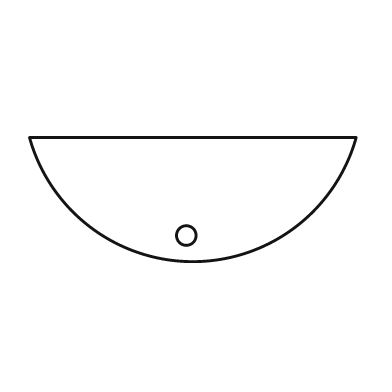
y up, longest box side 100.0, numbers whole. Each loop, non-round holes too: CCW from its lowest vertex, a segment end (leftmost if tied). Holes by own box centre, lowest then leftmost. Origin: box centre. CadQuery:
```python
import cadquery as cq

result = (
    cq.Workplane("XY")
    .moveTo(-50.0, 19.0)
    .threePointArc((0.0, -19.0), (50.0, 19.0))
    .close()
    .moveTo(-2.0, -11.0)
    .circle(3.0)
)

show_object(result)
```